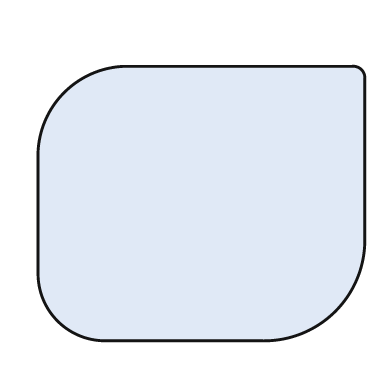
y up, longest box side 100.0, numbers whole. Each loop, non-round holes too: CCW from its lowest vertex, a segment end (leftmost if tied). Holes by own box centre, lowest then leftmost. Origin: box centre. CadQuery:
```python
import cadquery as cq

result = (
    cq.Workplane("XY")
    .moveTo(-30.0, -42.0)
    .lineTo(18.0, -42.0)
    .threePointArc((41.0, -33.0), (50.0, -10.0))
    .lineTo(50.0, 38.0)
    .threePointArc((49.0, 41.0), (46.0, 42.0))
    .lineTo(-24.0, 42.0)
    .threePointArc((-42.0, 34.0), (-50.0, 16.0))
    .lineTo(-50.0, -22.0)
    .threePointArc((-44.0, -36.0), (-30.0, -42.0))
    .close()
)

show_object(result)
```